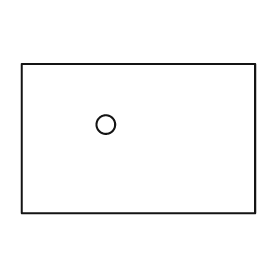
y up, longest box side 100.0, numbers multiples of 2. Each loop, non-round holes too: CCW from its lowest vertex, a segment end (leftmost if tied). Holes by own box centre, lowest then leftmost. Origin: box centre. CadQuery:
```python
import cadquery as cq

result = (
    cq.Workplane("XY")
    .moveTo(-50.0, -32.0)
    .lineTo(50.0, -32.0)
    .lineTo(50.0, 32.0)
    .lineTo(-50.0, 32.0)
    .close()
    .moveTo(-14.0, 6.0)
    .circle(4.0)
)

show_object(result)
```